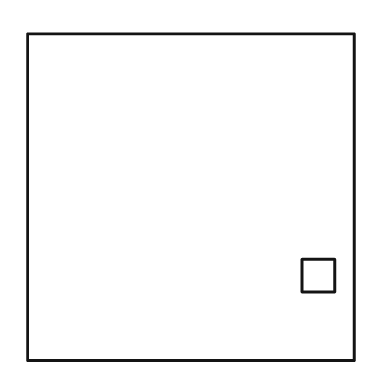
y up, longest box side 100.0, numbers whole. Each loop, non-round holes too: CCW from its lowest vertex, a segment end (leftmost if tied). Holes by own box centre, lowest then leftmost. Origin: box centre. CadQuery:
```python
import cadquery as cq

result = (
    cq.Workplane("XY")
    .moveTo(-50.0, -50.0)
    .lineTo(50.0, -50.0)
    .lineTo(50.0, 50.0)
    .lineTo(-50.0, 50.0)
    .close()
    .moveTo(34.0, -29.0)
    .lineTo(44.0, -29.0)
    .lineTo(44.0, -19.0)
    .lineTo(34.0, -19.0)
    .close()
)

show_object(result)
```